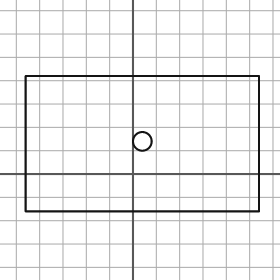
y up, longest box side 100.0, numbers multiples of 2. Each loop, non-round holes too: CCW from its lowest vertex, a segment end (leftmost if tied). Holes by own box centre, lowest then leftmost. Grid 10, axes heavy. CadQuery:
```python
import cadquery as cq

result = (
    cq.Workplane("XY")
    .moveTo(-46.0, -16.0)
    .lineTo(54.0, -16.0)
    .lineTo(54.0, 42.0)
    .lineTo(-46.0, 42.0)
    .close()
    .moveTo(4.0, 14.0)
    .circle(4.0)
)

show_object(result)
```